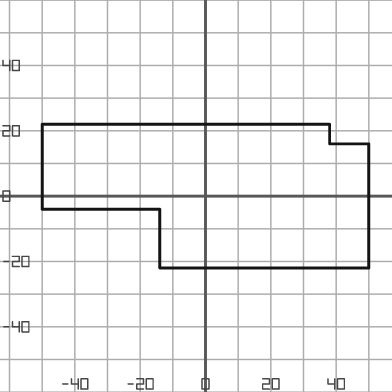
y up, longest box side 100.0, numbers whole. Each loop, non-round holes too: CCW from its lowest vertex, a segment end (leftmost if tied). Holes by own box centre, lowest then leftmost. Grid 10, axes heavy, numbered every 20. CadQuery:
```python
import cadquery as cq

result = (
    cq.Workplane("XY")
    .moveTo(-14.0, -22.0)
    .lineTo(50.0, -22.0)
    .lineTo(50.0, 16.0)
    .lineTo(38.0, 16.0)
    .lineTo(38.0, 22.0)
    .lineTo(-50.0, 22.0)
    .lineTo(-50.0, -4.0)
    .lineTo(-14.0, -4.0)
    .close()
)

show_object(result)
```